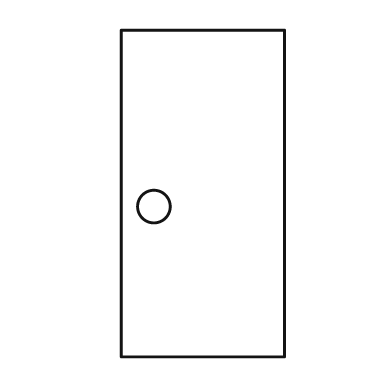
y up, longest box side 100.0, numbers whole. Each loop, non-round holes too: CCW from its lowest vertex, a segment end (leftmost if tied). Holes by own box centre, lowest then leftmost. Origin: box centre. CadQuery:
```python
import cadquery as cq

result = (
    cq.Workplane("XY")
    .moveTo(-25.0, -50.0)
    .lineTo(25.0, -50.0)
    .lineTo(25.0, 50.0)
    .lineTo(-25.0, 50.0)
    .close()
    .moveTo(-15.0, -4.0)
    .circle(5.0)
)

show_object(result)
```